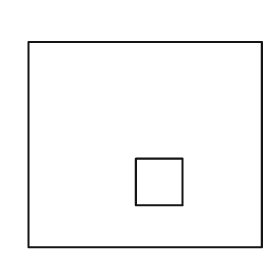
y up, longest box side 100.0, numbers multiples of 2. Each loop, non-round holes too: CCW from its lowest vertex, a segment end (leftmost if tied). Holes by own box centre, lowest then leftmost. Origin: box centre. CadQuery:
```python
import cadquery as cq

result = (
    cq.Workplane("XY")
    .moveTo(-50.0, -44.0)
    .lineTo(50.0, -44.0)
    .lineTo(50.0, 44.0)
    .lineTo(-50.0, 44.0)
    .close()
    .moveTo(-4.0, -26.0)
    .lineTo(16.0, -26.0)
    .lineTo(16.0, -6.0)
    .lineTo(-4.0, -6.0)
    .close()
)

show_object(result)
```